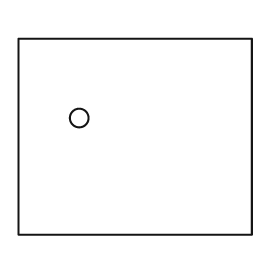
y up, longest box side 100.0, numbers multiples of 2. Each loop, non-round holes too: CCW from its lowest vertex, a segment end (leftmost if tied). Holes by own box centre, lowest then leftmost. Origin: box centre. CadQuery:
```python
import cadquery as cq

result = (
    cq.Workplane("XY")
    .moveTo(-50.0, -42.0)
    .lineTo(50.0, -42.0)
    .lineTo(50.0, 42.0)
    .lineTo(-50.0, 42.0)
    .close()
    .moveTo(-24.0, 8.0)
    .circle(4.0)
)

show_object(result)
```